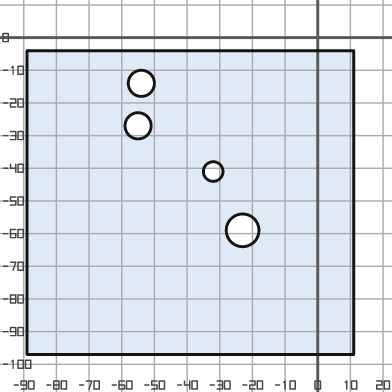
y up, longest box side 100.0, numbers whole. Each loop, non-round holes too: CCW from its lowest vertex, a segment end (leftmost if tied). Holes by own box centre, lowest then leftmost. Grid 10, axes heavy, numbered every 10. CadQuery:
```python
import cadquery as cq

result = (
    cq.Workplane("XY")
    .moveTo(-89.0, -97.0)
    .lineTo(11.0, -97.0)
    .lineTo(11.0, -4.0)
    .lineTo(-89.0, -4.0)
    .close()
    .moveTo(-23.0, -59.0)
    .circle(5.0)
    .moveTo(-32.0, -41.0)
    .circle(3.0)
    .moveTo(-55.0, -27.0)
    .circle(4.0)
    .moveTo(-54.0, -14.0)
    .circle(4.0)
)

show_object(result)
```